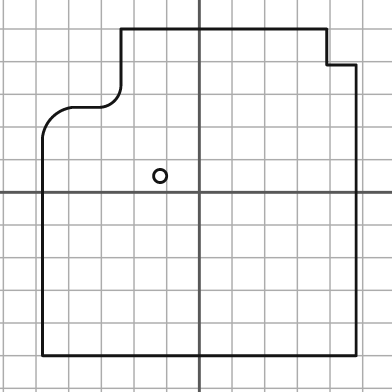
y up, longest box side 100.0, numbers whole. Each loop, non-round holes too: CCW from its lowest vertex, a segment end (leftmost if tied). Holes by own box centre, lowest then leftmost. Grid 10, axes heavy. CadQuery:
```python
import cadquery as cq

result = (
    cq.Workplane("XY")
    .moveTo(-48.0, -50.0)
    .lineTo(48.0, -50.0)
    .lineTo(48.0, 39.0)
    .lineTo(39.0, 39.0)
    .lineTo(39.0, 50.0)
    .lineTo(-24.0, 50.0)
    .lineTo(-24.0, 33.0)
    .threePointArc((-26.0, 28.0), (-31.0, 26.0))
    .lineTo(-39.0, 26.0)
    .threePointArc((-45.0, 23.0), (-48.0, 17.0))
    .close()
    .moveTo(-12.0, 5.0)
    .circle(2.0)
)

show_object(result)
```